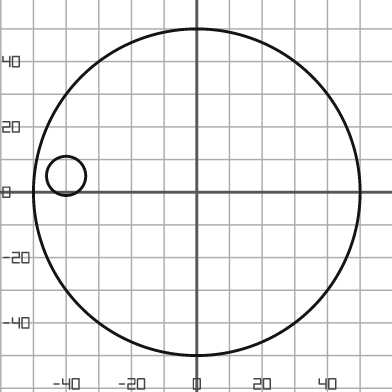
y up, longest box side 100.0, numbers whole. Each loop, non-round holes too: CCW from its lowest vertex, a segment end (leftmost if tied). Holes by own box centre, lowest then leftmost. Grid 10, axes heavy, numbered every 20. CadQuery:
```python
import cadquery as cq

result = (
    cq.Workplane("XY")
    .moveTo(0.0, 0.0)
    .circle(50.0)
    .moveTo(-40.0, 5.0)
    .circle(6.0)
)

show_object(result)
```